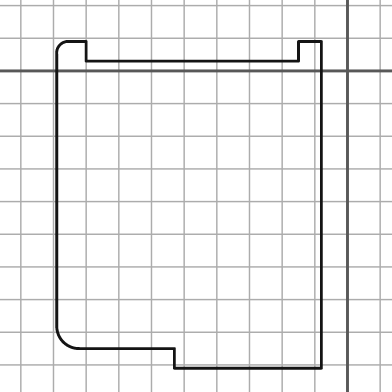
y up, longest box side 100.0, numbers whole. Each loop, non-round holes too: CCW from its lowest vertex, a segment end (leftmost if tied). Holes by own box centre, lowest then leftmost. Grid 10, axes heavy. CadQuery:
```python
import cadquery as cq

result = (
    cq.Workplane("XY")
    .moveTo(-53.0, -91.0)
    .lineTo(-8.0, -91.0)
    .lineTo(-8.0, 9.0)
    .lineTo(-15.0, 9.0)
    .lineTo(-15.0, 3.0)
    .lineTo(-80.0, 3.0)
    .lineTo(-80.0, 9.0)
    .lineTo(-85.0, 9.0)
    .threePointArc((-88.0, 8.0), (-89.0, 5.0))
    .lineTo(-89.0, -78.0)
    .threePointArc((-87.0, -83.0), (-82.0, -85.0))
    .lineTo(-53.0, -85.0)
    .close()
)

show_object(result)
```